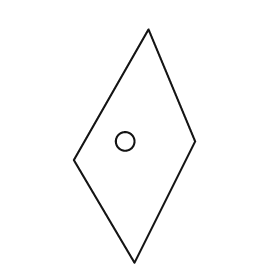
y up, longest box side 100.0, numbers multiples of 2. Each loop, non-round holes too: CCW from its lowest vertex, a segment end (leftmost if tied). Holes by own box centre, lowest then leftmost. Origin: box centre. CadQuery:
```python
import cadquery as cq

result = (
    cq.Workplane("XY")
    .moveTo(0.0, -50.0)
    .lineTo(26.0, 2.0)
    .lineTo(6.0, 50.0)
    .lineTo(-26.0, -6.0)
    .close()
    .moveTo(-4.0, 2.0)
    .circle(4.0)
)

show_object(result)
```